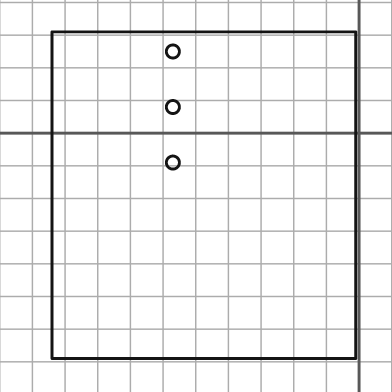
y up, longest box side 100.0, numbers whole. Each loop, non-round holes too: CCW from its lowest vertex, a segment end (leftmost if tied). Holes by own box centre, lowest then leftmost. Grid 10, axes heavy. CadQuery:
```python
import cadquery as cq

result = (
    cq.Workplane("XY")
    .moveTo(-94.0, -69.0)
    .lineTo(-1.0, -69.0)
    .lineTo(-1.0, 31.0)
    .lineTo(-94.0, 31.0)
    .close()
    .moveTo(-57.0, -9.0)
    .circle(2.0)
    .moveTo(-57.0, 8.0)
    .circle(2.0)
    .moveTo(-57.0, 25.0)
    .circle(2.0)
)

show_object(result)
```